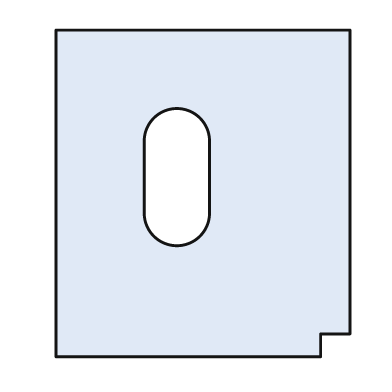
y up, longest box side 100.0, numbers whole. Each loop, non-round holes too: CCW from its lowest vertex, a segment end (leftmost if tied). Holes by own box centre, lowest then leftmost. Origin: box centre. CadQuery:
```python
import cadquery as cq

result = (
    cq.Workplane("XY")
    .moveTo(-45.0, -50.0)
    .lineTo(36.0, -50.0)
    .lineTo(36.0, -43.0)
    .lineTo(45.0, -43.0)
    .lineTo(45.0, 50.0)
    .lineTo(-45.0, 50.0)
    .close()
    .moveTo(-18.0, -6.0)
    .threePointArc((-8.0, -16.0), (2.0, -6.0))
    .lineTo(2.0, 16.0)
    .threePointArc((-8.0, 26.0), (-18.0, 16.0))
    .close()
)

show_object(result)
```